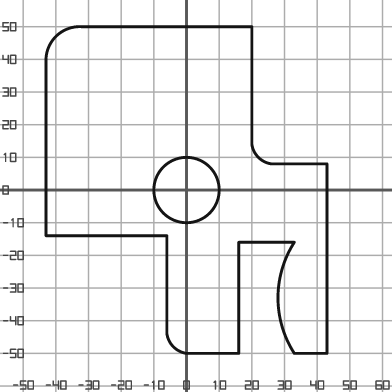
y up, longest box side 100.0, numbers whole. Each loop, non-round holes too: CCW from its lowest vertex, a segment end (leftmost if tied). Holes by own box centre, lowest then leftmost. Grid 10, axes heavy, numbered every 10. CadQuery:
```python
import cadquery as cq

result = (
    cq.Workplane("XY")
    .moveTo(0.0, -50.0)
    .lineTo(16.0, -50.0)
    .lineTo(16.0, -16.0)
    .lineTo(33.0, -16.0)
    .threePointArc((28.0, -33.0), (33.0, -50.0))
    .lineTo(43.0, -50.0)
    .lineTo(43.0, 8.0)
    .lineTo(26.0, 8.0)
    .threePointArc((22.0, 10.0), (20.0, 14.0))
    .lineTo(20.0, 50.0)
    .lineTo(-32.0, 50.0)
    .threePointArc((-40.0, 47.0), (-43.0, 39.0))
    .lineTo(-43.0, -14.0)
    .lineTo(-6.0, -14.0)
    .lineTo(-6.0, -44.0)
    .threePointArc((-4.0, -48.0), (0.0, -50.0))
    .close()
    .moveTo(0.0, 0.0)
    .circle(10.0)
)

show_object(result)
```